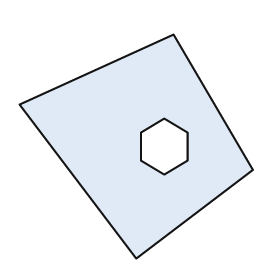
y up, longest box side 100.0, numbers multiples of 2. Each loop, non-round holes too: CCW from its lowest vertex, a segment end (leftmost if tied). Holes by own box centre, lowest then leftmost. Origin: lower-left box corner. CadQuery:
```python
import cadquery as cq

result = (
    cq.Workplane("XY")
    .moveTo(50.0, 0.0)
    .lineTo(100.0, 38.0)
    .lineTo(66.0, 96.0)
    .lineTo(0.0, 66.0)
    .close()
    .moveTo(62.0, 36.0)
    .lineTo(72.0, 42.0)
    .lineTo(72.0, 54.0)
    .lineTo(62.0, 60.0)
    .lineTo(52.0, 54.0)
    .lineTo(52.0, 42.0)
    .close()
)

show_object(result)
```